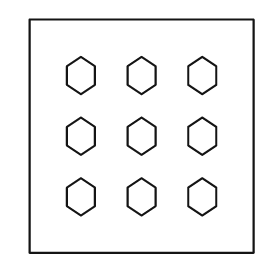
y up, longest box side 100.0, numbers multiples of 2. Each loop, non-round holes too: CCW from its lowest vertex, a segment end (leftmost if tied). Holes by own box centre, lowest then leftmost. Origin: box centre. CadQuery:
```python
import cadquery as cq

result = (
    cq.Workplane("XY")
    .moveTo(-48.0, -50.0)
    .lineTo(48.0, -50.0)
    .lineTo(48.0, 50.0)
    .lineTo(-48.0, 50.0)
    .close()
    .moveTo(-26.0, -34.0)
    .lineTo(-20.0, -30.0)
    .lineTo(-20.0, -22.0)
    .lineTo(-26.0, -18.0)
    .lineTo(-32.0, -22.0)
    .lineTo(-32.0, -30.0)
    .close()
    .moveTo(0.0, -34.0)
    .lineTo(6.0, -30.0)
    .lineTo(6.0, -22.0)
    .lineTo(0.0, -18.0)
    .lineTo(-6.0, -22.0)
    .lineTo(-6.0, -30.0)
    .close()
    .moveTo(26.0, -34.0)
    .lineTo(32.0, -30.0)
    .lineTo(32.0, -22.0)
    .lineTo(26.0, -18.0)
    .lineTo(20.0, -22.0)
    .lineTo(20.0, -30.0)
    .close()
    .moveTo(-26.0, -8.0)
    .lineTo(-20.0, -4.0)
    .lineTo(-20.0, 4.0)
    .lineTo(-26.0, 8.0)
    .lineTo(-32.0, 4.0)
    .lineTo(-32.0, -4.0)
    .close()
    .moveTo(0.0, -8.0)
    .lineTo(6.0, -4.0)
    .lineTo(6.0, 4.0)
    .lineTo(0.0, 8.0)
    .lineTo(-6.0, 4.0)
    .lineTo(-6.0, -4.0)
    .close()
    .moveTo(26.0, -8.0)
    .lineTo(32.0, -4.0)
    .lineTo(32.0, 4.0)
    .lineTo(26.0, 8.0)
    .lineTo(20.0, 4.0)
    .lineTo(20.0, -4.0)
    .close()
    .moveTo(-26.0, 18.0)
    .lineTo(-20.0, 22.0)
    .lineTo(-20.0, 30.0)
    .lineTo(-26.0, 34.0)
    .lineTo(-32.0, 30.0)
    .lineTo(-32.0, 22.0)
    .close()
    .moveTo(0.0, 18.0)
    .lineTo(6.0, 22.0)
    .lineTo(6.0, 30.0)
    .lineTo(0.0, 34.0)
    .lineTo(-6.0, 30.0)
    .lineTo(-6.0, 22.0)
    .close()
    .moveTo(26.0, 18.0)
    .lineTo(32.0, 22.0)
    .lineTo(32.0, 30.0)
    .lineTo(26.0, 34.0)
    .lineTo(20.0, 30.0)
    .lineTo(20.0, 22.0)
    .close()
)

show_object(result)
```